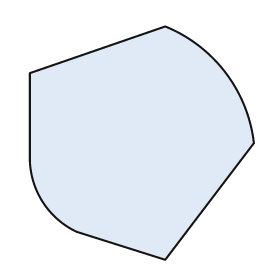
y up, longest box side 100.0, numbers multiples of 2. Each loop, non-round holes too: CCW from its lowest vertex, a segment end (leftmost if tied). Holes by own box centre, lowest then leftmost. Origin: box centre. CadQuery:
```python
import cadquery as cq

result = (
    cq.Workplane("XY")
    .moveTo(10.0, -50.0)
    .lineTo(48.0, 0.0)
    .threePointArc((36.0, 30.0), (10.0, 50.0))
    .lineTo(-48.0, 30.0)
    .lineTo(-48.0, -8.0)
    .threePointArc((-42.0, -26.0), (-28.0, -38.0))
    .close()
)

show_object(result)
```